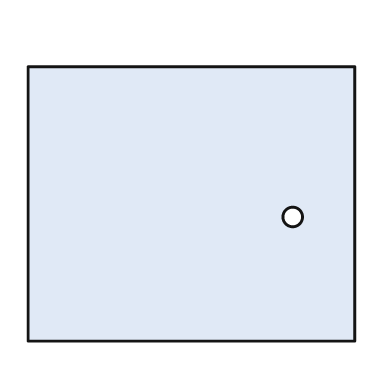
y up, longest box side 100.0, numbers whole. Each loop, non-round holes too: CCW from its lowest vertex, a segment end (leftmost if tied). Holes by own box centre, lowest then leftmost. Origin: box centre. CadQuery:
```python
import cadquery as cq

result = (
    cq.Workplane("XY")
    .moveTo(-50.0, -42.0)
    .lineTo(50.0, -42.0)
    .lineTo(50.0, 42.0)
    .lineTo(-50.0, 42.0)
    .close()
    .moveTo(31.0, -4.0)
    .circle(3.0)
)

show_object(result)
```